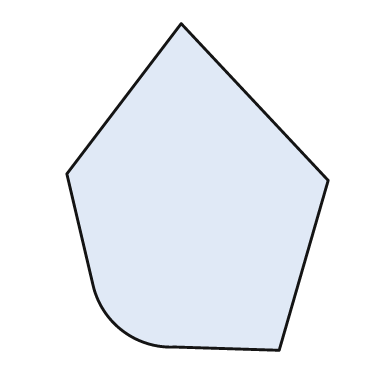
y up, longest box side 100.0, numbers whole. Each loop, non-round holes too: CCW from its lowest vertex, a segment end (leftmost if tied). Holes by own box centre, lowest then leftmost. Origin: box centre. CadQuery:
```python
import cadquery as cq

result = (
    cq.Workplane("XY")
    .moveTo(25.0, -50.0)
    .lineTo(40.0, 2.0)
    .lineTo(-5.0, 50.0)
    .lineTo(-40.0, 4.0)
    .lineTo(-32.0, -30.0)
    .threePointArc((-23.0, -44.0), (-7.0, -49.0))
    .close()
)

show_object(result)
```